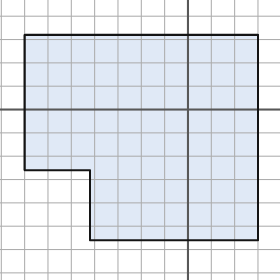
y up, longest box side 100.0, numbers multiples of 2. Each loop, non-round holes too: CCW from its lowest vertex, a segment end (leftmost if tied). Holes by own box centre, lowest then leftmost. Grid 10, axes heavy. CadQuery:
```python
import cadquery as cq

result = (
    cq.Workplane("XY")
    .moveTo(-42.0, -56.0)
    .lineTo(30.0, -56.0)
    .lineTo(30.0, 32.0)
    .lineTo(-70.0, 32.0)
    .lineTo(-70.0, -26.0)
    .lineTo(-42.0, -26.0)
    .close()
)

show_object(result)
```